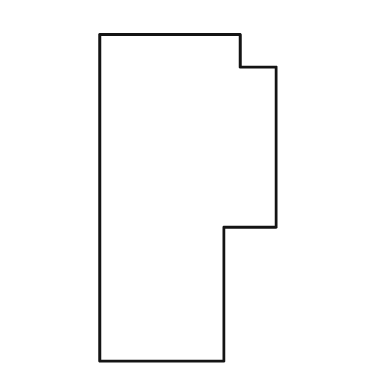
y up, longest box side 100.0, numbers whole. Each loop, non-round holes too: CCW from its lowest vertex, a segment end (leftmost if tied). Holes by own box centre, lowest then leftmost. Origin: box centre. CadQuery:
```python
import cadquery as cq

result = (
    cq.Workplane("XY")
    .moveTo(-27.0, -50.0)
    .lineTo(11.0, -50.0)
    .lineTo(11.0, -9.0)
    .lineTo(27.0, -9.0)
    .lineTo(27.0, 40.0)
    .lineTo(16.0, 40.0)
    .lineTo(16.0, 50.0)
    .lineTo(-27.0, 50.0)
    .close()
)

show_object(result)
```